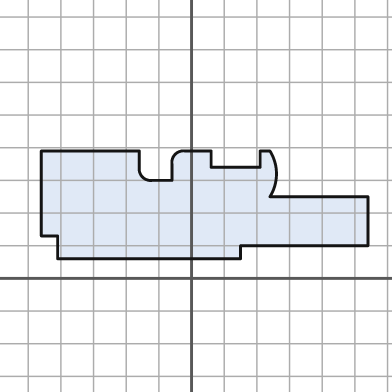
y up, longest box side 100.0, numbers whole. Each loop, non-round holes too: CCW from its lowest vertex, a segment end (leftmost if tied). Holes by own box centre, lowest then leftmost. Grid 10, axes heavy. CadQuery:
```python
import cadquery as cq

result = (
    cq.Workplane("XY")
    .moveTo(-41.0, 6.0)
    .lineTo(15.0, 6.0)
    .lineTo(15.0, 10.0)
    .lineTo(54.0, 10.0)
    .lineTo(54.0, 25.0)
    .lineTo(24.0, 25.0)
    .threePointArc((26.0, 32.0), (24.0, 39.0))
    .lineTo(21.0, 39.0)
    .lineTo(21.0, 34.0)
    .lineTo(6.0, 34.0)
    .lineTo(6.0, 39.0)
    .lineTo(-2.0, 39.0)
    .threePointArc((-5.0, 38.0), (-6.0, 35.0))
    .lineTo(-6.0, 30.0)
    .lineTo(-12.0, 30.0)
    .threePointArc((-15.0, 31.0), (-16.0, 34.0))
    .lineTo(-16.0, 39.0)
    .lineTo(-46.0, 39.0)
    .lineTo(-46.0, 13.0)
    .lineTo(-41.0, 13.0)
    .close()
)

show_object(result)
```